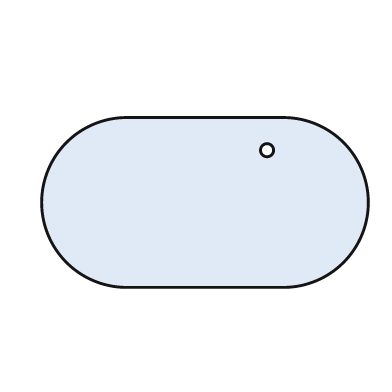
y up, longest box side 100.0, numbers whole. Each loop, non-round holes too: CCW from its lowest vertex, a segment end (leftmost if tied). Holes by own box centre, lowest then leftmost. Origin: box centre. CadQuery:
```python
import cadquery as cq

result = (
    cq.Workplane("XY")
    .moveTo(-24.0, -26.0)
    .lineTo(24.0, -26.0)
    .threePointArc((50.0, 0.0), (24.0, 26.0))
    .lineTo(-24.0, 26.0)
    .threePointArc((-50.0, 0.0), (-24.0, -26.0))
    .close()
    .moveTo(19.0, 16.0)
    .circle(2.0)
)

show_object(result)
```